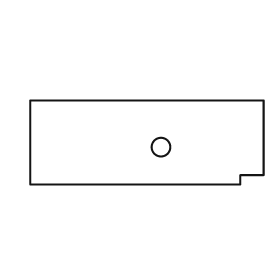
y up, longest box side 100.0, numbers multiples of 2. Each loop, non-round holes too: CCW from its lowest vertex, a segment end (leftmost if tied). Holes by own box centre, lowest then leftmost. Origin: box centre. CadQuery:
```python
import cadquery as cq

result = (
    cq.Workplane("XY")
    .moveTo(-50.0, -18.0)
    .lineTo(40.0, -18.0)
    .lineTo(40.0, -14.0)
    .lineTo(50.0, -14.0)
    .lineTo(50.0, 18.0)
    .lineTo(-50.0, 18.0)
    .close()
    .moveTo(6.0, -2.0)
    .circle(4.0)
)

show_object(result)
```